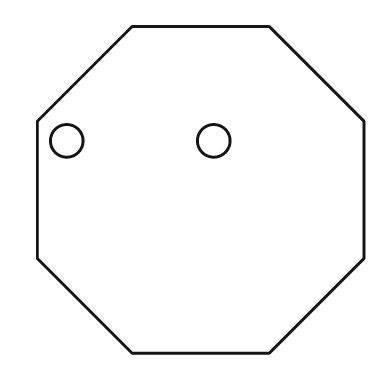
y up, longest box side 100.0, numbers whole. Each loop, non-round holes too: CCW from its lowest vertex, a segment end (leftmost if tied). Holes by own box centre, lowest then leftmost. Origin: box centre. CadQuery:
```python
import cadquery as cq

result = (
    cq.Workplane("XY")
    .moveTo(-21.0, -50.0)
    .lineTo(21.0, -50.0)
    .lineTo(50.0, -21.0)
    .lineTo(50.0, 21.0)
    .lineTo(21.0, 50.0)
    .lineTo(-21.0, 50.0)
    .lineTo(-50.0, 21.0)
    .lineTo(-50.0, -21.0)
    .close()
    .moveTo(-41.0, 15.0)
    .circle(5.0)
    .moveTo(4.0, 15.0)
    .circle(5.0)
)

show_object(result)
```